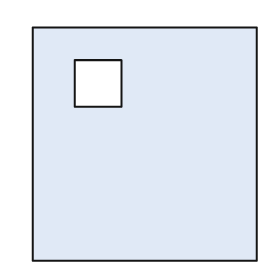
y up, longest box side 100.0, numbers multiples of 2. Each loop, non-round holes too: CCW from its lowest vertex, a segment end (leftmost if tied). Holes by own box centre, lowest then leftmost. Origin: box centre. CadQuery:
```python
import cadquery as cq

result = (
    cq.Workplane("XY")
    .moveTo(-48.0, -50.0)
    .lineTo(48.0, -50.0)
    .lineTo(48.0, 50.0)
    .lineTo(-48.0, 50.0)
    .close()
    .moveTo(-30.0, 16.0)
    .lineTo(-10.0, 16.0)
    .lineTo(-10.0, 36.0)
    .lineTo(-30.0, 36.0)
    .close()
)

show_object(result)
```